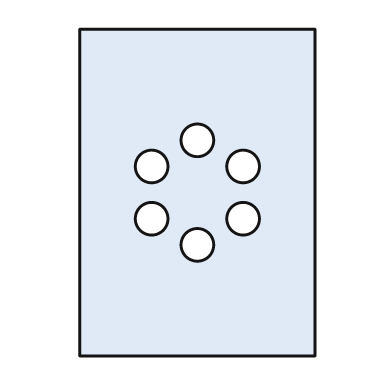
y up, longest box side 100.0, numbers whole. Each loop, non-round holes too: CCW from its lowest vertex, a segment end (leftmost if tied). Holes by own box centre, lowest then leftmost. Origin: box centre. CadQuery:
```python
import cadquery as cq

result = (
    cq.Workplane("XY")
    .moveTo(-36.0, -50.0)
    .lineTo(36.0, -50.0)
    .lineTo(36.0, 50.0)
    .lineTo(-36.0, 50.0)
    .close()
    .moveTo(0.0, -16.0)
    .circle(5.0)
    .moveTo(-14.0, -8.0)
    .circle(5.0)
    .moveTo(14.0, -8.0)
    .circle(5.0)
    .moveTo(-14.0, 8.0)
    .circle(5.0)
    .moveTo(14.0, 8.0)
    .circle(5.0)
    .moveTo(0.0, 16.0)
    .circle(5.0)
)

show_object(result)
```